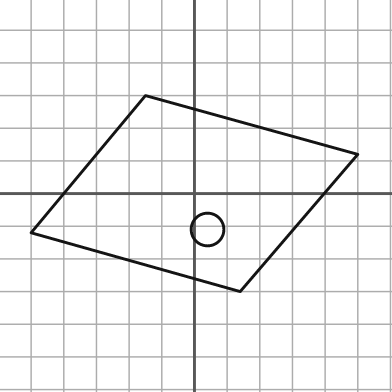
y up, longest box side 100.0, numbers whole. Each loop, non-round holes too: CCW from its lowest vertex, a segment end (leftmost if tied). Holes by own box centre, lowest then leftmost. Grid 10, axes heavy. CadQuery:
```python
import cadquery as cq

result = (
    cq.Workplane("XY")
    .moveTo(14.0, -30.0)
    .lineTo(50.0, 12.0)
    .lineTo(-15.0, 30.0)
    .lineTo(-50.0, -12.0)
    .close()
    .moveTo(4.0, -11.0)
    .circle(5.0)
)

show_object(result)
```